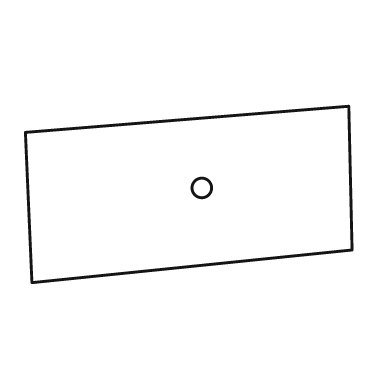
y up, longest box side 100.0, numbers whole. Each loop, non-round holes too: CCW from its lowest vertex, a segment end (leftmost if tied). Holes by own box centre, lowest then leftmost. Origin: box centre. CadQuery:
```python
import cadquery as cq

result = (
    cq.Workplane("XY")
    .moveTo(-48.0, -27.0)
    .lineTo(50.0, -17.0)
    .lineTo(49.0, 27.0)
    .lineTo(-50.0, 19.0)
    .close()
    .moveTo(4.0, 2.0)
    .circle(3.0)
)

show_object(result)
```